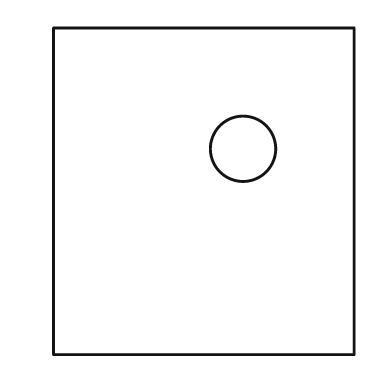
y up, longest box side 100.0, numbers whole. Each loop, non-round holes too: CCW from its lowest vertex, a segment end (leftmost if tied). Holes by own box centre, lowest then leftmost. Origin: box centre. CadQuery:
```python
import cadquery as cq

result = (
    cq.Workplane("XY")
    .moveTo(-46.0, -50.0)
    .lineTo(46.0, -50.0)
    .lineTo(46.0, 50.0)
    .lineTo(-46.0, 50.0)
    .close()
    .moveTo(12.0, 13.0)
    .circle(10.0)
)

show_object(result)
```